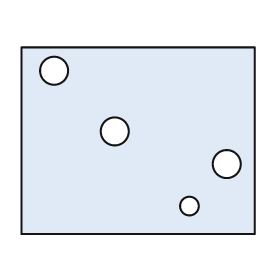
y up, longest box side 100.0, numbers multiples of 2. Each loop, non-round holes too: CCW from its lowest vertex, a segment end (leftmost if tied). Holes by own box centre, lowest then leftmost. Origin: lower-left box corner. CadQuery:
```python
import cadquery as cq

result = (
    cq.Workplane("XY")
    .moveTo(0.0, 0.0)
    .lineTo(100.0, 0.0)
    .lineTo(100.0, 80.0)
    .lineTo(0.0, 80.0)
    .close()
    .moveTo(72.0, 12.0)
    .circle(4.0)
    .moveTo(88.0, 30.0)
    .circle(6.0)
    .moveTo(40.0, 44.0)
    .circle(6.0)
    .moveTo(14.0, 70.0)
    .circle(6.0)
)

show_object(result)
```